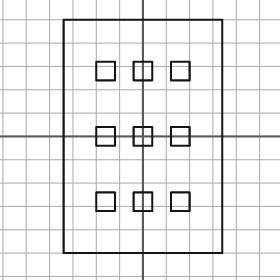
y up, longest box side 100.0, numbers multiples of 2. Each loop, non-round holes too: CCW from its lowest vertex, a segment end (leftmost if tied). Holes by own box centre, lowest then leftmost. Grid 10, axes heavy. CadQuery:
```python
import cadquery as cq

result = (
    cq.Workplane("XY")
    .moveTo(-34.0, -50.0)
    .lineTo(34.0, -50.0)
    .lineTo(34.0, 50.0)
    .lineTo(-34.0, 50.0)
    .close()
    .moveTo(-20.0, -32.0)
    .lineTo(-12.0, -32.0)
    .lineTo(-12.0, -24.0)
    .lineTo(-20.0, -24.0)
    .close()
    .moveTo(-4.0, -32.0)
    .lineTo(4.0, -32.0)
    .lineTo(4.0, -24.0)
    .lineTo(-4.0, -24.0)
    .close()
    .moveTo(12.0, -32.0)
    .lineTo(20.0, -32.0)
    .lineTo(20.0, -24.0)
    .lineTo(12.0, -24.0)
    .close()
    .moveTo(-20.0, -4.0)
    .lineTo(-12.0, -4.0)
    .lineTo(-12.0, 4.0)
    .lineTo(-20.0, 4.0)
    .close()
    .moveTo(-4.0, -4.0)
    .lineTo(4.0, -4.0)
    .lineTo(4.0, 4.0)
    .lineTo(-4.0, 4.0)
    .close()
    .moveTo(12.0, -4.0)
    .lineTo(20.0, -4.0)
    .lineTo(20.0, 4.0)
    .lineTo(12.0, 4.0)
    .close()
    .moveTo(-20.0, 24.0)
    .lineTo(-12.0, 24.0)
    .lineTo(-12.0, 32.0)
    .lineTo(-20.0, 32.0)
    .close()
    .moveTo(-4.0, 24.0)
    .lineTo(4.0, 24.0)
    .lineTo(4.0, 32.0)
    .lineTo(-4.0, 32.0)
    .close()
    .moveTo(12.0, 24.0)
    .lineTo(20.0, 24.0)
    .lineTo(20.0, 32.0)
    .lineTo(12.0, 32.0)
    .close()
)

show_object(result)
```